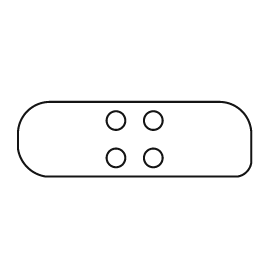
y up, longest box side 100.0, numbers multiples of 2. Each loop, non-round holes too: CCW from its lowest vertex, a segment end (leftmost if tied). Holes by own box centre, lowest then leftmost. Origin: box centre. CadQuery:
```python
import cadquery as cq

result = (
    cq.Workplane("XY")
    .moveTo(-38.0, -16.0)
    .lineTo(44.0, -16.0)
    .threePointArc((48.0, -14.0), (50.0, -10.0))
    .lineTo(50.0, 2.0)
    .threePointArc((46.0, 12.0), (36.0, 16.0))
    .lineTo(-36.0, 16.0)
    .threePointArc((-46.0, 12.0), (-50.0, 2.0))
    .lineTo(-50.0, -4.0)
    .threePointArc((-46.0, -12.0), (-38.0, -16.0))
    .close()
    .moveTo(-8.0, -8.0)
    .circle(4.0)
    .moveTo(8.0, -8.0)
    .circle(4.0)
    .moveTo(-8.0, 8.0)
    .circle(4.0)
    .moveTo(8.0, 8.0)
    .circle(4.0)
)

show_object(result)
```